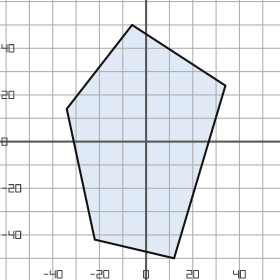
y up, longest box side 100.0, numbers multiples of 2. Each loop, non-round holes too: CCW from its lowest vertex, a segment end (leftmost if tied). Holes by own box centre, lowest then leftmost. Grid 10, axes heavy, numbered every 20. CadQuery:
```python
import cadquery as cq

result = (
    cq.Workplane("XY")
    .moveTo(12.0, -50.0)
    .lineTo(34.0, 24.0)
    .lineTo(-6.0, 50.0)
    .lineTo(-34.0, 14.0)
    .lineTo(-22.0, -42.0)
    .close()
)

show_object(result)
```